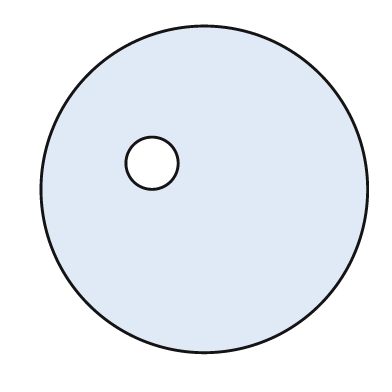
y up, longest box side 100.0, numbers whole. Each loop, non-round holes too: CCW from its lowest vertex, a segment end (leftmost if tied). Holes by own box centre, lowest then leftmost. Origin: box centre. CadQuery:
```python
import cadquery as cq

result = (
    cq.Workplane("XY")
    .moveTo(0.0, 0.0)
    .circle(50.0)
    .moveTo(-16.0, 8.0)
    .circle(8.0)
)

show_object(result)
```